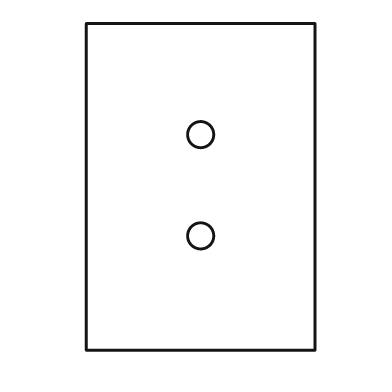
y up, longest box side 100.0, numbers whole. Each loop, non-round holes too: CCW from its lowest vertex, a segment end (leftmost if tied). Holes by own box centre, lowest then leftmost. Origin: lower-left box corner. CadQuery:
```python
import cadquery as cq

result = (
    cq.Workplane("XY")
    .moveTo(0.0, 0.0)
    .lineTo(70.0, 0.0)
    .lineTo(70.0, 100.0)
    .lineTo(0.0, 100.0)
    .close()
    .moveTo(35.0, 35.0)
    .circle(4.0)
    .moveTo(35.0, 66.0)
    .circle(4.0)
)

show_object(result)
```